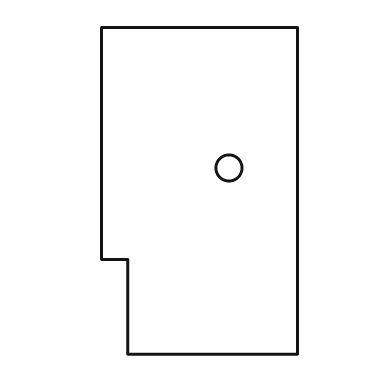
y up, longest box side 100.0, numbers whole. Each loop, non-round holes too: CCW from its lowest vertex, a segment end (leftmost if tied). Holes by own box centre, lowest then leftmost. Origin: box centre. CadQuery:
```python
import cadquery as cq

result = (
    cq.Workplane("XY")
    .moveTo(-22.0, -50.0)
    .lineTo(30.0, -50.0)
    .lineTo(30.0, 50.0)
    .lineTo(-30.0, 50.0)
    .lineTo(-30.0, -21.0)
    .lineTo(-22.0, -21.0)
    .close()
    .moveTo(9.0, 7.0)
    .circle(4.0)
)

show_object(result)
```